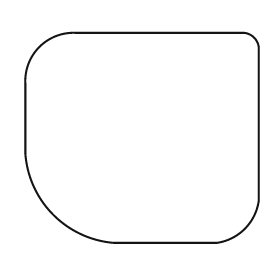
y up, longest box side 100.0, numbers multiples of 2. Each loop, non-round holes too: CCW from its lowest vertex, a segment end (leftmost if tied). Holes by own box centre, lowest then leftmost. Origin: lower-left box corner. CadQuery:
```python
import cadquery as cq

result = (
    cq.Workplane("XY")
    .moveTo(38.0, 0.0)
    .lineTo(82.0, 0.0)
    .threePointArc((94.0, 6.0), (100.0, 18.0))
    .lineTo(100.0, 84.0)
    .threePointArc((98.0, 88.0), (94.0, 90.0))
    .lineTo(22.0, 90.0)
    .threePointArc((6.0, 84.0), (0.0, 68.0))
    .lineTo(0.0, 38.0)
    .threePointArc((12.0, 12.0), (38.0, 0.0))
    .close()
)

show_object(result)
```